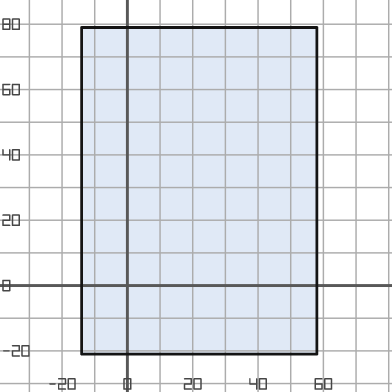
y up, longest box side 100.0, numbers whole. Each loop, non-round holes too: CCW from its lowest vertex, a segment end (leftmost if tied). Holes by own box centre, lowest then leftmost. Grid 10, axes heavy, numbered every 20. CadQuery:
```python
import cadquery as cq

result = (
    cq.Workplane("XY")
    .moveTo(-14.0, -21.0)
    .lineTo(58.0, -21.0)
    .lineTo(58.0, 79.0)
    .lineTo(-14.0, 79.0)
    .close()
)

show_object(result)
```